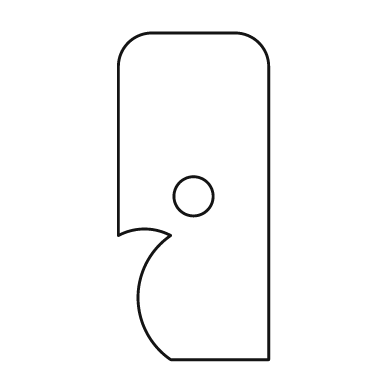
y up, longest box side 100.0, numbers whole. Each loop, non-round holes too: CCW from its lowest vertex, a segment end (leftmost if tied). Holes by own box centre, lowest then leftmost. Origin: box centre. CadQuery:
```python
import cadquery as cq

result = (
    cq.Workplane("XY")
    .moveTo(-7.0, -50.0)
    .lineTo(23.0, -50.0)
    .lineTo(23.0, 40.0)
    .threePointArc((20.0, 47.0), (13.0, 50.0))
    .lineTo(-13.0, 50.0)
    .threePointArc((-20.0, 47.0), (-23.0, 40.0))
    .lineTo(-23.0, -12.0)
    .threePointArc((-15.0, -10.0), (-7.0, -12.0))
    .threePointArc((-17.0, -31.0), (-7.0, -50.0))
    .close()
    .moveTo(0.0, 0.0)
    .circle(6.0)
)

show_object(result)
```